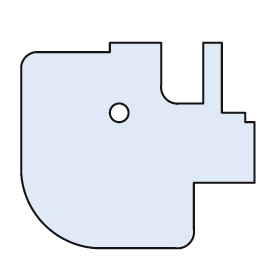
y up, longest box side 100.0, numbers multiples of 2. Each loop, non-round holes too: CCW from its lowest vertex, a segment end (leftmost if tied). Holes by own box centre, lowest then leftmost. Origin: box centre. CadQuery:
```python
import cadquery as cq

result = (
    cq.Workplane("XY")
    .moveTo(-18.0, -44.0)
    .lineTo(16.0, -44.0)
    .threePointArc((22.0, -42.0), (24.0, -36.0))
    .lineTo(24.0, -16.0)
    .lineTo(50.0, -16.0)
    .lineTo(50.0, 10.0)
    .lineTo(46.0, 10.0)
    .lineTo(46.0, 14.0)
    .lineTo(36.0, 14.0)
    .lineTo(36.0, 44.0)
    .lineTo(28.0, 44.0)
    .lineTo(28.0, 18.0)
    .lineTo(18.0, 18.0)
    .threePointArc((12.0, 20.0), (10.0, 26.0))
    .lineTo(10.0, 44.0)
    .lineTo(-12.0, 44.0)
    .lineTo(-12.0, 40.0)
    .lineTo(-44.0, 40.0)
    .threePointArc((-48.0, 38.0), (-50.0, 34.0))
    .lineTo(-50.0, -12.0)
    .threePointArc((-40.0, -34.0), (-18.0, -44.0))
    .close()
    .moveTo(-8.0, 14.0)
    .circle(4.0)
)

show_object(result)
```